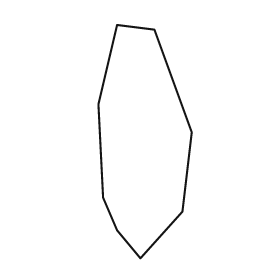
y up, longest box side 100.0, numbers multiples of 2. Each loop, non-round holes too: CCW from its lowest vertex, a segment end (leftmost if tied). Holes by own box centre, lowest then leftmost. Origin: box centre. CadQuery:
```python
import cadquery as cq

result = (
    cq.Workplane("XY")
    .moveTo(-2.0, -50.0)
    .lineTo(16.0, -30.0)
    .lineTo(20.0, 4.0)
    .lineTo(4.0, 48.0)
    .lineTo(-12.0, 50.0)
    .lineTo(-20.0, 16.0)
    .lineTo(-18.0, -24.0)
    .lineTo(-12.0, -38.0)
    .close()
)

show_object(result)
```